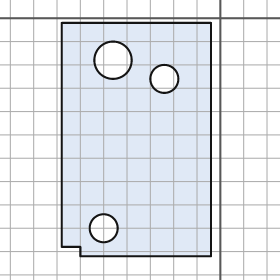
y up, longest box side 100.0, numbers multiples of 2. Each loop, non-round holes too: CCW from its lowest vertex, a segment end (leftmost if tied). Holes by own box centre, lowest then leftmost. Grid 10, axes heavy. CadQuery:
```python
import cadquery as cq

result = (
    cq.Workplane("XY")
    .moveTo(-60.0, -102.0)
    .lineTo(-4.0, -102.0)
    .lineTo(-4.0, -2.0)
    .lineTo(-68.0, -2.0)
    .lineTo(-68.0, -98.0)
    .lineTo(-60.0, -98.0)
    .close()
    .moveTo(-50.0, -90.0)
    .circle(6.0)
    .moveTo(-24.0, -26.0)
    .circle(6.0)
    .moveTo(-46.0, -18.0)
    .circle(8.0)
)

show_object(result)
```